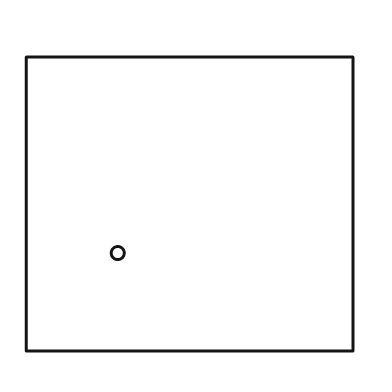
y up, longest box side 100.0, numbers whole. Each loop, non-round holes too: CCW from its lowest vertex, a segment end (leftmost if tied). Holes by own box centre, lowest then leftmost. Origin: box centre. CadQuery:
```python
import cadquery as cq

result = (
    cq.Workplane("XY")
    .moveTo(-50.0, -45.0)
    .lineTo(50.0, -45.0)
    .lineTo(50.0, 45.0)
    .lineTo(-50.0, 45.0)
    .close()
    .moveTo(-22.0, -15.0)
    .circle(2.0)
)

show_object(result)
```